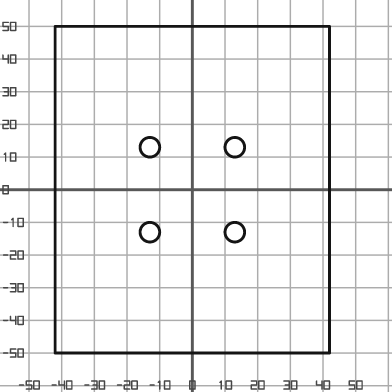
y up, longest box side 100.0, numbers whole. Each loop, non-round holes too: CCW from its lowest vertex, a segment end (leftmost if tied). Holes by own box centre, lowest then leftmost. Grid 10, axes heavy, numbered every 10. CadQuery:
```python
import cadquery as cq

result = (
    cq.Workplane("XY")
    .moveTo(-42.0, -50.0)
    .lineTo(42.0, -50.0)
    .lineTo(42.0, 50.0)
    .lineTo(-42.0, 50.0)
    .close()
    .moveTo(-13.0, -13.0)
    .circle(3.0)
    .moveTo(13.0, -13.0)
    .circle(3.0)
    .moveTo(-13.0, 13.0)
    .circle(3.0)
    .moveTo(13.0, 13.0)
    .circle(3.0)
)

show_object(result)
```